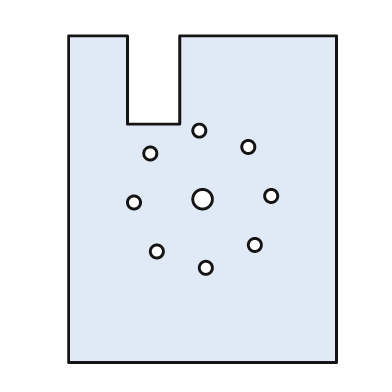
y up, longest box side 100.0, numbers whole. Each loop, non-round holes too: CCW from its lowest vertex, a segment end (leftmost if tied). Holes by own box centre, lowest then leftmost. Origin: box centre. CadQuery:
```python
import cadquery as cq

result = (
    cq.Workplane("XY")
    .moveTo(-41.0, -50.0)
    .lineTo(41.0, -50.0)
    .lineTo(41.0, 50.0)
    .lineTo(-7.0, 50.0)
    .lineTo(-7.0, 23.0)
    .lineTo(-23.0, 23.0)
    .lineTo(-23.0, 50.0)
    .lineTo(-41.0, 50.0)
    .close()
    .moveTo(1.0, -21.0)
    .circle(2.0)
    .moveTo(-14.0, -16.0)
    .circle(2.0)
    .moveTo(16.0, -14.0)
    .circle(2.0)
    .moveTo(-21.0, -1.0)
    .circle(2.0)
    .moveTo(0.0, 0.0)
    .circle(3.0)
    .moveTo(21.0, 1.0)
    .circle(2.0)
    .moveTo(-16.0, 14.0)
    .circle(2.0)
    .moveTo(14.0, 16.0)
    .circle(2.0)
    .moveTo(-1.0, 21.0)
    .circle(2.0)
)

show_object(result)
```